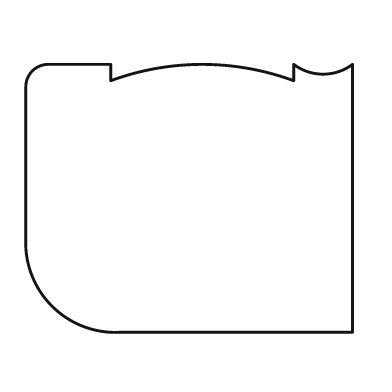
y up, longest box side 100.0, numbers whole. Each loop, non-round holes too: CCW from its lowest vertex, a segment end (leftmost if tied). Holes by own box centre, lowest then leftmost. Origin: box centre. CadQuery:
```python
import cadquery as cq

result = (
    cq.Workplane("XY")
    .moveTo(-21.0, -41.0)
    .lineTo(50.0, -41.0)
    .lineTo(50.0, 41.0)
    .threePointArc((41.0, 38.0), (32.0, 41.0))
    .lineTo(32.0, 36.0)
    .threePointArc((4.0, 41.0), (-24.0, 36.0))
    .lineTo(-24.0, 41.0)
    .lineTo(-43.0, 41.0)
    .threePointArc((-48.0, 39.0), (-50.0, 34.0))
    .lineTo(-50.0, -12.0)
    .threePointArc((-42.0, -33.0), (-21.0, -41.0))
    .close()
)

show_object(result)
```